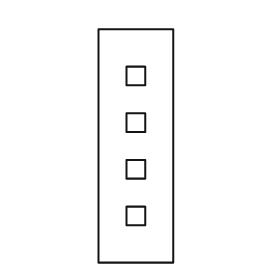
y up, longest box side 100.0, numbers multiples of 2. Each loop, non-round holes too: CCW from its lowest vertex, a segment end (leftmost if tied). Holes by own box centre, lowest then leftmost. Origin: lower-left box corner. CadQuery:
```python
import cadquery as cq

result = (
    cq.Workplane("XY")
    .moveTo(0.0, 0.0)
    .lineTo(32.0, 0.0)
    .lineTo(32.0, 100.0)
    .lineTo(0.0, 100.0)
    .close()
    .moveTo(12.0, 16.0)
    .lineTo(20.0, 16.0)
    .lineTo(20.0, 24.0)
    .lineTo(12.0, 24.0)
    .close()
    .moveTo(12.0, 36.0)
    .lineTo(20.0, 36.0)
    .lineTo(20.0, 44.0)
    .lineTo(12.0, 44.0)
    .close()
    .moveTo(12.0, 56.0)
    .lineTo(20.0, 56.0)
    .lineTo(20.0, 64.0)
    .lineTo(12.0, 64.0)
    .close()
    .moveTo(12.0, 76.0)
    .lineTo(20.0, 76.0)
    .lineTo(20.0, 84.0)
    .lineTo(12.0, 84.0)
    .close()
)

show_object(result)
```